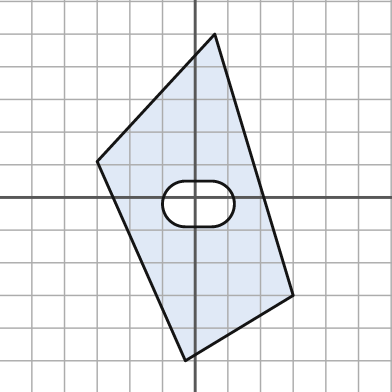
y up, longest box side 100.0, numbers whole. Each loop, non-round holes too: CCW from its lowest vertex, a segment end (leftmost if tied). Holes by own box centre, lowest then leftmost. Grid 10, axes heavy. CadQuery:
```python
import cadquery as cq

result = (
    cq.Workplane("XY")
    .moveTo(-3.0, -50.0)
    .lineTo(30.0, -30.0)
    .lineTo(6.0, 50.0)
    .lineTo(-30.0, 11.0)
    .close()
    .moveTo(-3.0, -9.0)
    .lineTo(5.0, -9.0)
    .threePointArc((12.0, -2.0), (5.0, 5.0))
    .lineTo(-3.0, 5.0)
    .threePointArc((-10.0, -2.0), (-3.0, -9.0))
    .close()
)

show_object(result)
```